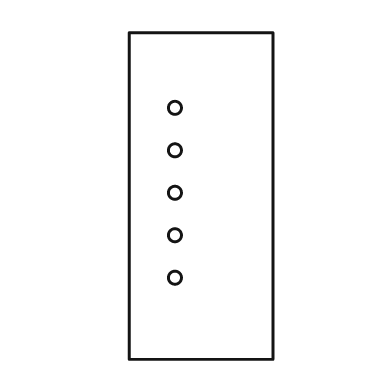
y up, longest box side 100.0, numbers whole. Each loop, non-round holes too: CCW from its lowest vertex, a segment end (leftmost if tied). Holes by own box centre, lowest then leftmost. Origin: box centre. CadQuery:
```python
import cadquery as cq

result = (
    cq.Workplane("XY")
    .moveTo(-22.0, -50.0)
    .lineTo(22.0, -50.0)
    .lineTo(22.0, 50.0)
    .lineTo(-22.0, 50.0)
    .close()
    .moveTo(-8.0, -25.0)
    .circle(2.0)
    .moveTo(-8.0, -12.0)
    .circle(2.0)
    .moveTo(-8.0, 1.0)
    .circle(2.0)
    .moveTo(-8.0, 14.0)
    .circle(2.0)
    .moveTo(-8.0, 27.0)
    .circle(2.0)
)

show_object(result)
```